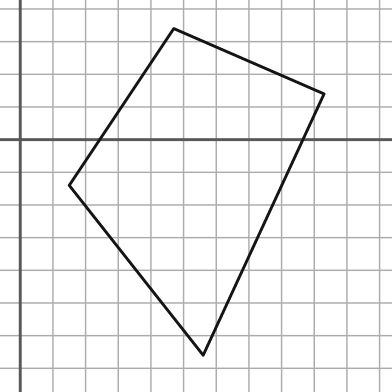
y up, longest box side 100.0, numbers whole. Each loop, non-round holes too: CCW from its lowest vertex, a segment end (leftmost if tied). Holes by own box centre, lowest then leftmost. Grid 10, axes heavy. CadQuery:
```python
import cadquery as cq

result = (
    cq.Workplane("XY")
    .moveTo(56.0, -66.0)
    .lineTo(93.0, 14.0)
    .lineTo(47.0, 34.0)
    .lineTo(15.0, -14.0)
    .close()
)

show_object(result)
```